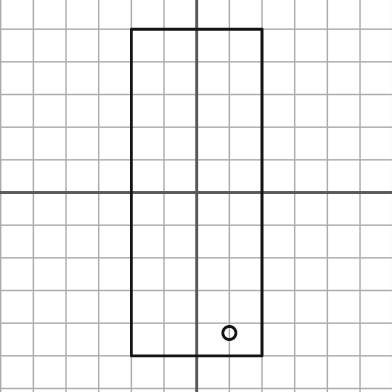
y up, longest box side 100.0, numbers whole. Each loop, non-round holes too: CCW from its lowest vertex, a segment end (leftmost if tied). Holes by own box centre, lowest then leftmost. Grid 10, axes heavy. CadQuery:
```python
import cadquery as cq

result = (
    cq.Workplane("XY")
    .moveTo(-20.0, -50.0)
    .lineTo(20.0, -50.0)
    .lineTo(20.0, 50.0)
    .lineTo(-20.0, 50.0)
    .close()
    .moveTo(10.0, -43.0)
    .circle(2.0)
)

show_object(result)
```